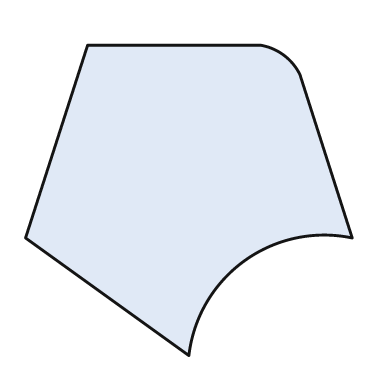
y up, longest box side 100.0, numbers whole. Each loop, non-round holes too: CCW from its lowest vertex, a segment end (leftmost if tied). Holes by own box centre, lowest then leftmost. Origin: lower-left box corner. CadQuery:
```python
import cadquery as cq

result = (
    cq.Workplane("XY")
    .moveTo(50.0, 0.0)
    .threePointArc((67.0, 29.0), (100.0, 36.0))
    .lineTo(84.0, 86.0)
    .threePointArc((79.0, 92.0), (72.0, 95.0))
    .lineTo(19.0, 95.0)
    .lineTo(0.0, 36.0)
    .close()
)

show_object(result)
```